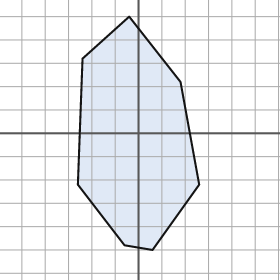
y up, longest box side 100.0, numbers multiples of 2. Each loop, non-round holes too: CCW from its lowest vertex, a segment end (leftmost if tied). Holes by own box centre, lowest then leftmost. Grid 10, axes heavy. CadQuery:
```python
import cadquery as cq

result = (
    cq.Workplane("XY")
    .moveTo(6.0, -50.0)
    .lineTo(26.0, -22.0)
    .lineTo(18.0, 22.0)
    .lineTo(-4.0, 50.0)
    .lineTo(-24.0, 32.0)
    .lineTo(-26.0, -22.0)
    .lineTo(-6.0, -48.0)
    .close()
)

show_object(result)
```